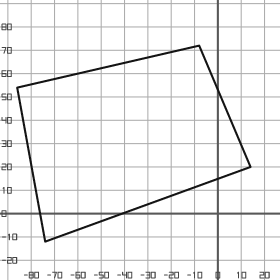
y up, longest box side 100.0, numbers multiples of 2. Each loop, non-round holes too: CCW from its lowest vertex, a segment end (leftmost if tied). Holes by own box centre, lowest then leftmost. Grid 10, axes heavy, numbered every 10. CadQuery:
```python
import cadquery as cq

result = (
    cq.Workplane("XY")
    .moveTo(-74.0, -12.0)
    .lineTo(14.0, 20.0)
    .lineTo(-8.0, 72.0)
    .lineTo(-86.0, 54.0)
    .close()
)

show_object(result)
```